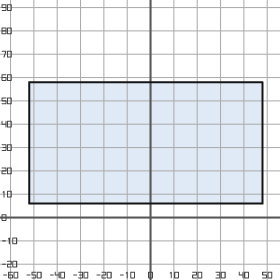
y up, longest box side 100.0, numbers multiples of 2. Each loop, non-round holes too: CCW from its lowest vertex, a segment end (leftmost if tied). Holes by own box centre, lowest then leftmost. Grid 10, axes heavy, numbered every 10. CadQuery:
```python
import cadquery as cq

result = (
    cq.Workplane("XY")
    .moveTo(-52.0, 6.0)
    .lineTo(48.0, 6.0)
    .lineTo(48.0, 58.0)
    .lineTo(-52.0, 58.0)
    .close()
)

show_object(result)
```